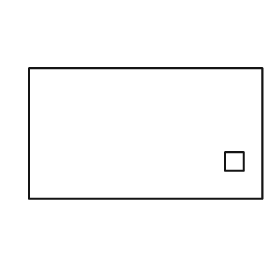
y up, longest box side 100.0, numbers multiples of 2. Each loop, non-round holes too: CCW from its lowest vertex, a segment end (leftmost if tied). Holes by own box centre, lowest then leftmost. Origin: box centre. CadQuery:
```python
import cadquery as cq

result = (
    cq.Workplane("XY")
    .moveTo(-50.0, -28.0)
    .lineTo(50.0, -28.0)
    .lineTo(50.0, 28.0)
    .lineTo(-50.0, 28.0)
    .close()
    .moveTo(34.0, -16.0)
    .lineTo(42.0, -16.0)
    .lineTo(42.0, -8.0)
    .lineTo(34.0, -8.0)
    .close()
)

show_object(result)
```